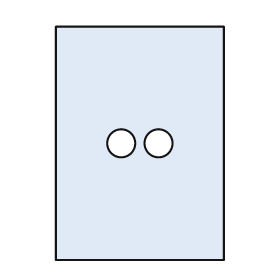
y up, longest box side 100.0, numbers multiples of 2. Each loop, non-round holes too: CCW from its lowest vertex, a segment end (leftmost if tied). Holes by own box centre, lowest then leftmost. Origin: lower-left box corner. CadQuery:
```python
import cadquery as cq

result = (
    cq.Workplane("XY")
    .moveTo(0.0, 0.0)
    .lineTo(72.0, 0.0)
    .lineTo(72.0, 100.0)
    .lineTo(0.0, 100.0)
    .close()
    .moveTo(28.0, 50.0)
    .circle(6.0)
    .moveTo(44.0, 50.0)
    .circle(6.0)
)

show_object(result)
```